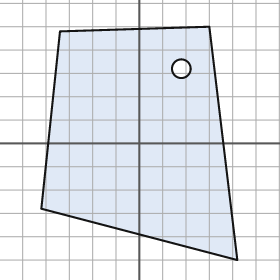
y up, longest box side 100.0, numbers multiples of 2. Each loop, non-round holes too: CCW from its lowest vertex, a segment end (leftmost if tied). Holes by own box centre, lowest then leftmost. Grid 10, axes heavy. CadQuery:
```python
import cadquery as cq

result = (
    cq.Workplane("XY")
    .moveTo(42.0, -50.0)
    .lineTo(30.0, 50.0)
    .lineTo(-34.0, 48.0)
    .lineTo(-42.0, -28.0)
    .close()
    .moveTo(18.0, 32.0)
    .circle(4.0)
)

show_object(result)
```